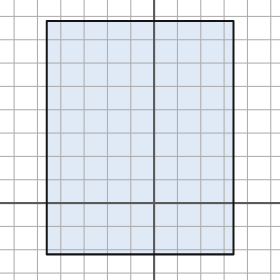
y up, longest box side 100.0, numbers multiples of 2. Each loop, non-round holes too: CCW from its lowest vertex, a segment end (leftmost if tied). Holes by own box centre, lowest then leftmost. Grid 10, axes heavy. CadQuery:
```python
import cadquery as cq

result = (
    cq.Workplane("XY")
    .moveTo(-46.0, -22.0)
    .lineTo(34.0, -22.0)
    .lineTo(34.0, 78.0)
    .lineTo(-46.0, 78.0)
    .close()
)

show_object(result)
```